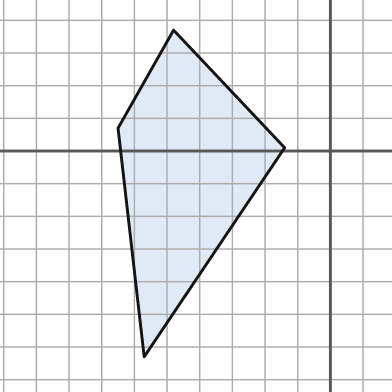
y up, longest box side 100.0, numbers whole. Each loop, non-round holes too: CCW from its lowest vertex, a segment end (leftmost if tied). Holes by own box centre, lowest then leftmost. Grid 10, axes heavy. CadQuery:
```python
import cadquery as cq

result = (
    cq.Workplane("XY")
    .moveTo(-57.0, -63.0)
    .lineTo(-14.0, 1.0)
    .lineTo(-48.0, 37.0)
    .lineTo(-65.0, 7.0)
    .close()
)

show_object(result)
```